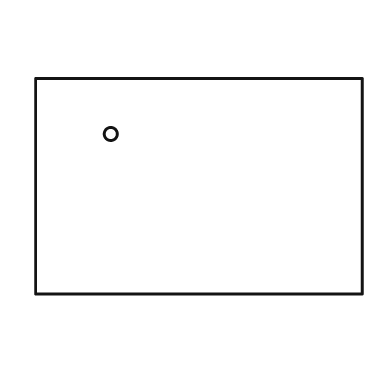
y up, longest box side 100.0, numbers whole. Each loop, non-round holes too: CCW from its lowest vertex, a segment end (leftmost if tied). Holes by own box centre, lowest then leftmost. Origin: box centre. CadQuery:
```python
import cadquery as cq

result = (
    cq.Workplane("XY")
    .moveTo(-50.0, -33.0)
    .lineTo(50.0, -33.0)
    .lineTo(50.0, 33.0)
    .lineTo(-50.0, 33.0)
    .close()
    .moveTo(-27.0, 16.0)
    .circle(2.0)
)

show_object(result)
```